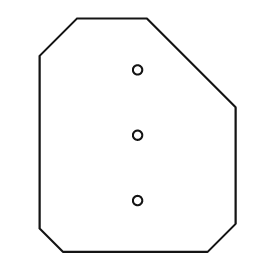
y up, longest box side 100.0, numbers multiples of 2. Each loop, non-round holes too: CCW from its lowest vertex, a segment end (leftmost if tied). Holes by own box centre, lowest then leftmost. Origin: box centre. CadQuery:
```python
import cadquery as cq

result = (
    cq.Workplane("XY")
    .moveTo(-32.0, -50.0)
    .lineTo(30.0, -50.0)
    .lineTo(42.0, -38.0)
    .lineTo(42.0, 12.0)
    .lineTo(4.0, 50.0)
    .lineTo(-26.0, 50.0)
    .lineTo(-42.0, 34.0)
    .lineTo(-42.0, -40.0)
    .close()
    .moveTo(0.0, -28.0)
    .circle(2.0)
    .moveTo(0.0, 0.0)
    .circle(2.0)
    .moveTo(0.0, 28.0)
    .circle(2.0)
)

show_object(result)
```